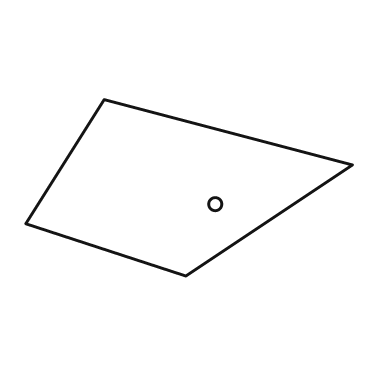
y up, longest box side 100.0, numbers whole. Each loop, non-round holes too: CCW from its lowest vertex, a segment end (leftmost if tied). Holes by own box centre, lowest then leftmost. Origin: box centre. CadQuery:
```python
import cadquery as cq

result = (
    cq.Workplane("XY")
    .moveTo(-1.0, -27.0)
    .lineTo(50.0, 7.0)
    .lineTo(-26.0, 27.0)
    .lineTo(-50.0, -11.0)
    .close()
    .moveTo(8.0, -5.0)
    .circle(2.0)
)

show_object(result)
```